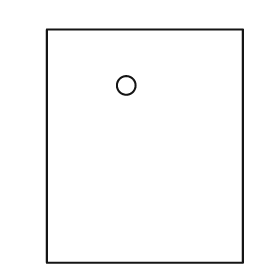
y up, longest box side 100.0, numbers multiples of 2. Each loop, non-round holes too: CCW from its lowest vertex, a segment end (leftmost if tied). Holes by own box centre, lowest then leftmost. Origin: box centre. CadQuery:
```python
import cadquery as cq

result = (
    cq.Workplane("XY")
    .moveTo(-42.0, -50.0)
    .lineTo(42.0, -50.0)
    .lineTo(42.0, 50.0)
    .lineTo(-42.0, 50.0)
    .close()
    .moveTo(-8.0, 26.0)
    .circle(4.0)
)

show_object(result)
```